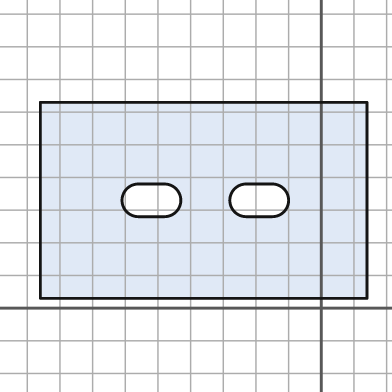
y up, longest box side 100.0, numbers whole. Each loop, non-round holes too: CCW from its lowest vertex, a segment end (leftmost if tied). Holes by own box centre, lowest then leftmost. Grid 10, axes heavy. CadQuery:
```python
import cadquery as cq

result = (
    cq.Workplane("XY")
    .moveTo(-86.0, 3.0)
    .lineTo(14.0, 3.0)
    .lineTo(14.0, 63.0)
    .lineTo(-86.0, 63.0)
    .close()
    .moveTo(-56.0, 28.0)
    .lineTo(-48.0, 28.0)
    .threePointArc((-43.0, 33.0), (-48.0, 38.0))
    .lineTo(-56.0, 38.0)
    .threePointArc((-61.0, 33.0), (-56.0, 28.0))
    .close()
    .moveTo(-23.0, 28.0)
    .lineTo(-15.0, 28.0)
    .threePointArc((-10.0, 33.0), (-15.0, 38.0))
    .lineTo(-23.0, 38.0)
    .threePointArc((-28.0, 33.0), (-23.0, 28.0))
    .close()
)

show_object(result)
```